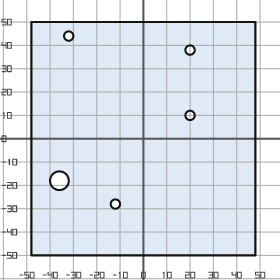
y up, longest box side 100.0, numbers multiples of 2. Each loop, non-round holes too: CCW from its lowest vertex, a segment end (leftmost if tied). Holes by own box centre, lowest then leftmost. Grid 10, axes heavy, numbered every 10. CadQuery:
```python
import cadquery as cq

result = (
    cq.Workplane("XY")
    .moveTo(-48.0, -50.0)
    .lineTo(48.0, -50.0)
    .lineTo(48.0, 50.0)
    .lineTo(-48.0, 50.0)
    .close()
    .moveTo(-12.0, -28.0)
    .circle(2.0)
    .moveTo(-36.0, -18.0)
    .circle(4.0)
    .moveTo(20.0, 10.0)
    .circle(2.0)
    .moveTo(20.0, 38.0)
    .circle(2.0)
    .moveTo(-32.0, 44.0)
    .circle(2.0)
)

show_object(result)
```